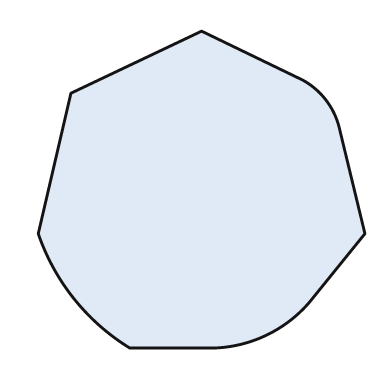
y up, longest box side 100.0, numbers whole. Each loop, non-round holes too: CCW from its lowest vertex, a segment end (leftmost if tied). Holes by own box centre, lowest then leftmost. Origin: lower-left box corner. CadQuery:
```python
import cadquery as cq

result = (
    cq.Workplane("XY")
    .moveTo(28.0, 0.0)
    .lineTo(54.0, 0.0)
    .threePointArc((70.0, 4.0), (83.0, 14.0))
    .lineTo(100.0, 35.0)
    .lineTo(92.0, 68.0)
    .threePointArc((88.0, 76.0), (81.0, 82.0))
    .lineTo(50.0, 97.0)
    .lineTo(10.0, 78.0)
    .lineTo(0.0, 35.0)
    .threePointArc((11.0, 15.0), (28.0, 0.0))
    .close()
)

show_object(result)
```